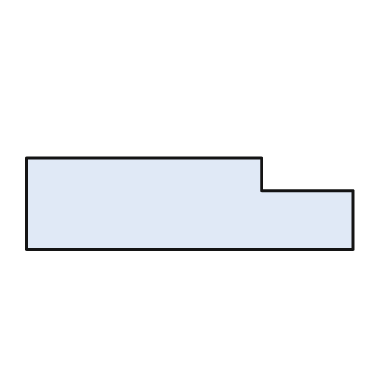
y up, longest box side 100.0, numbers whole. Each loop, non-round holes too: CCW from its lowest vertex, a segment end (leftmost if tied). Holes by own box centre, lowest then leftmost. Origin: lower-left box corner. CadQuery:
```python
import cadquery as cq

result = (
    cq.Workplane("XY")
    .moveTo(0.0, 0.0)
    .lineTo(100.0, 0.0)
    .lineTo(100.0, 18.0)
    .lineTo(72.0, 18.0)
    .lineTo(72.0, 28.0)
    .lineTo(0.0, 28.0)
    .close()
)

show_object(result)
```